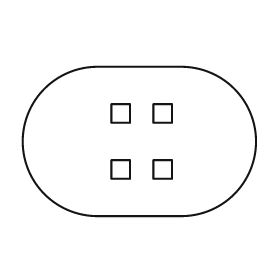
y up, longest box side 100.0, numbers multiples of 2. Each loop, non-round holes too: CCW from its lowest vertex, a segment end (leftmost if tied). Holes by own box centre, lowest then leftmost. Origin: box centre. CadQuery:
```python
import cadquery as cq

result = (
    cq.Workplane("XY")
    .moveTo(-18.0, -32.0)
    .lineTo(18.0, -32.0)
    .threePointArc((50.0, 0.0), (18.0, 32.0))
    .lineTo(-18.0, 32.0)
    .threePointArc((-50.0, 0.0), (-18.0, -32.0))
    .close()
    .moveTo(-12.0, -16.0)
    .lineTo(-4.0, -16.0)
    .lineTo(-4.0, -8.0)
    .lineTo(-12.0, -8.0)
    .close()
    .moveTo(6.0, -16.0)
    .lineTo(14.0, -16.0)
    .lineTo(14.0, -8.0)
    .lineTo(6.0, -8.0)
    .close()
    .moveTo(-12.0, 8.0)
    .lineTo(-4.0, 8.0)
    .lineTo(-4.0, 16.0)
    .lineTo(-12.0, 16.0)
    .close()
    .moveTo(6.0, 8.0)
    .lineTo(14.0, 8.0)
    .lineTo(14.0, 16.0)
    .lineTo(6.0, 16.0)
    .close()
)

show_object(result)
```